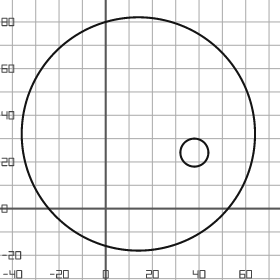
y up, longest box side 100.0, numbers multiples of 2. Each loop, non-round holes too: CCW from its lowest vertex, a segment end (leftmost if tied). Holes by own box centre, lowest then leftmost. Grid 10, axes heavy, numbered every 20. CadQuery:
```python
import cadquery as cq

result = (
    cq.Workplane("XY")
    .moveTo(14.0, 32.0)
    .circle(50.0)
    .moveTo(38.0, 24.0)
    .circle(6.0)
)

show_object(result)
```